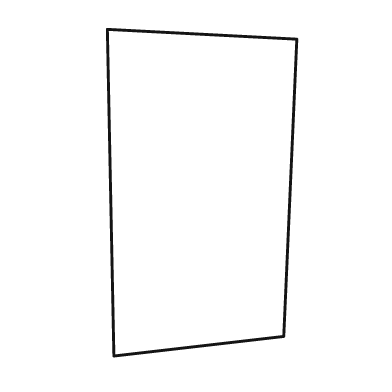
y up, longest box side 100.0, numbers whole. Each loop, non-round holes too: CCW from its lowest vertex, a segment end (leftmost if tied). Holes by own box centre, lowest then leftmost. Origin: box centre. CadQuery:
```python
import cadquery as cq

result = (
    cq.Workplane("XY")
    .moveTo(-27.0, -50.0)
    .lineTo(25.0, -44.0)
    .lineTo(29.0, 47.0)
    .lineTo(-29.0, 50.0)
    .close()
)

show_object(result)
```